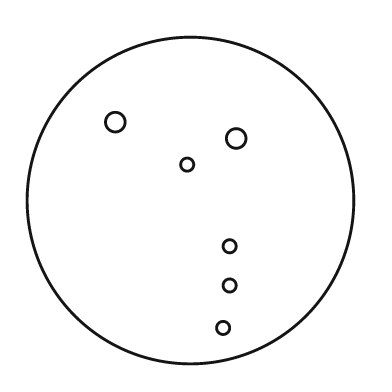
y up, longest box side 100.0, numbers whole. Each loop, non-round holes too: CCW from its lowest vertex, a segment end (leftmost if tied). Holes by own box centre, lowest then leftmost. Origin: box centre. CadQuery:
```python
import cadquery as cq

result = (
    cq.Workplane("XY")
    .moveTo(0.0, 0.0)
    .circle(50.0)
    .moveTo(10.0, -39.0)
    .circle(2.0)
    .moveTo(12.0, -26.0)
    .circle(2.0)
    .moveTo(12.0, -14.0)
    .circle(2.0)
    .moveTo(-1.0, 11.0)
    .circle(2.0)
    .moveTo(14.0, 19.0)
    .circle(3.0)
    .moveTo(-23.0, 24.0)
    .circle(3.0)
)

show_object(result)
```